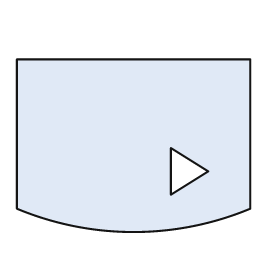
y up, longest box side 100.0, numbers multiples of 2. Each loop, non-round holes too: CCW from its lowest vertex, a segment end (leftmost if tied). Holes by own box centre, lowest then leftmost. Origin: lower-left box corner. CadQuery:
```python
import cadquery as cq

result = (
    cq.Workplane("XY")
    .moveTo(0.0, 10.0)
    .threePointArc((50.0, 0.0), (100.0, 10.0))
    .lineTo(100.0, 74.0)
    .lineTo(0.0, 74.0)
    .close()
    .moveTo(66.0, 16.0)
    .lineTo(82.0, 26.0)
    .lineTo(66.0, 36.0)
    .close()
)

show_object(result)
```